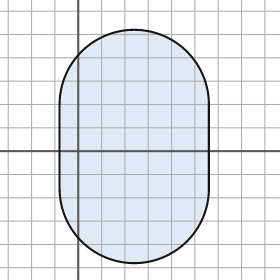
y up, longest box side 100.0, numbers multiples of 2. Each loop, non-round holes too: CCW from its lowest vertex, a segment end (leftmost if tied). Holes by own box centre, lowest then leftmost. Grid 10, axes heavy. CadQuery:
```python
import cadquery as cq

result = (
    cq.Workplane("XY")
    .moveTo(-8.0, -16.0)
    .threePointArc((24.0, -48.0), (56.0, -16.0))
    .lineTo(56.0, 20.0)
    .threePointArc((24.0, 52.0), (-8.0, 20.0))
    .close()
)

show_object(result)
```